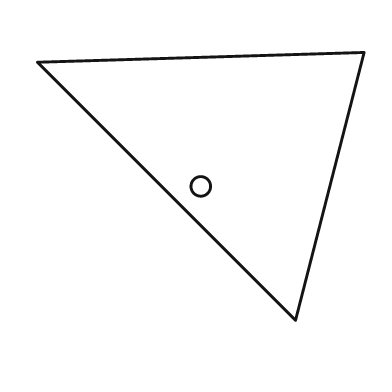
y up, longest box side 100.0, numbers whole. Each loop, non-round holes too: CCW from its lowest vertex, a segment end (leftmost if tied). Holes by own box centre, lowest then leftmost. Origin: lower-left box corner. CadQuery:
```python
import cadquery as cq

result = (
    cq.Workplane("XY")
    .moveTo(79.0, 0.0)
    .lineTo(100.0, 82.0)
    .lineTo(0.0, 79.0)
    .close()
    .moveTo(50.0, 41.0)
    .circle(3.0)
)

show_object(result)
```